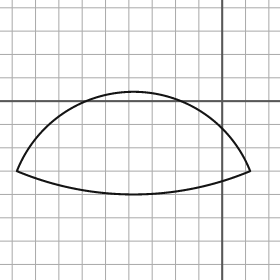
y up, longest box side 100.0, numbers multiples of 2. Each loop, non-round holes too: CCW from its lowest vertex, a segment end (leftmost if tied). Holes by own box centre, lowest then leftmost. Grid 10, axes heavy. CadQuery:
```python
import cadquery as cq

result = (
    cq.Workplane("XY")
    .moveTo(-88.0, -30.0)
    .threePointArc((-38.0, -40.0), (12.0, -30.0))
    .threePointArc((-38.0, 4.0), (-88.0, -30.0))
    .close()
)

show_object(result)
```